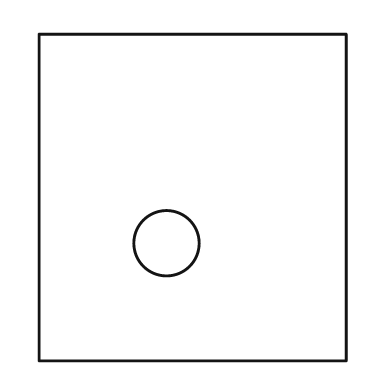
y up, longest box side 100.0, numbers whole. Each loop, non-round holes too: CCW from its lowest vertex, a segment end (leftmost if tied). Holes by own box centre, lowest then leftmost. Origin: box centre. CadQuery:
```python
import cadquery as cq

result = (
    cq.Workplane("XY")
    .moveTo(-47.0, -50.0)
    .lineTo(47.0, -50.0)
    .lineTo(47.0, 50.0)
    .lineTo(-47.0, 50.0)
    .close()
    .moveTo(-8.0, -14.0)
    .circle(10.0)
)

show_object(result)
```